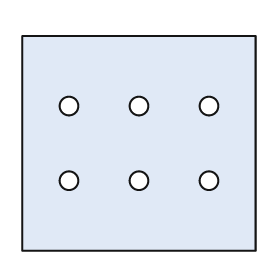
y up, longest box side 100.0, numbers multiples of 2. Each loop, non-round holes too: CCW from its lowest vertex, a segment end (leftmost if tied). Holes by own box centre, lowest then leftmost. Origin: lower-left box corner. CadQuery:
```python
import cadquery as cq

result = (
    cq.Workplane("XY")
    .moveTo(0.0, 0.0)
    .lineTo(100.0, 0.0)
    .lineTo(100.0, 92.0)
    .lineTo(0.0, 92.0)
    .close()
    .moveTo(20.0, 30.0)
    .circle(4.0)
    .moveTo(50.0, 30.0)
    .circle(4.0)
    .moveTo(80.0, 30.0)
    .circle(4.0)
    .moveTo(20.0, 62.0)
    .circle(4.0)
    .moveTo(50.0, 62.0)
    .circle(4.0)
    .moveTo(80.0, 62.0)
    .circle(4.0)
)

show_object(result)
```